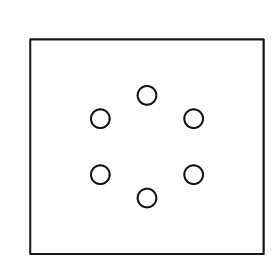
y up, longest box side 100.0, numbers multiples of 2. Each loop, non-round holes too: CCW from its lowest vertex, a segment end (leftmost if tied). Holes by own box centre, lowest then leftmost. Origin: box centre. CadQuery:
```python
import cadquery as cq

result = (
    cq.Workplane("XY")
    .moveTo(-50.0, -46.0)
    .lineTo(50.0, -46.0)
    .lineTo(50.0, 46.0)
    .lineTo(-50.0, 46.0)
    .close()
    .moveTo(0.0, -22.0)
    .circle(4.0)
    .moveTo(-20.0, -12.0)
    .circle(4.0)
    .moveTo(20.0, -12.0)
    .circle(4.0)
    .moveTo(-20.0, 12.0)
    .circle(4.0)
    .moveTo(20.0, 12.0)
    .circle(4.0)
    .moveTo(0.0, 22.0)
    .circle(4.0)
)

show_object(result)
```